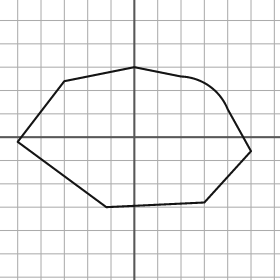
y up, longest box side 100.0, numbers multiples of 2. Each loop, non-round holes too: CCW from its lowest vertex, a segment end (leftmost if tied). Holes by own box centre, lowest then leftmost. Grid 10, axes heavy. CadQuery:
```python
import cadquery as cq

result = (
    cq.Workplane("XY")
    .moveTo(-12.0, -30.0)
    .lineTo(30.0, -28.0)
    .lineTo(50.0, -6.0)
    .lineTo(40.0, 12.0)
    .threePointArc((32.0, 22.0), (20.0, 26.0))
    .lineTo(0.0, 30.0)
    .lineTo(-30.0, 24.0)
    .lineTo(-50.0, -2.0)
    .close()
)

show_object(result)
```